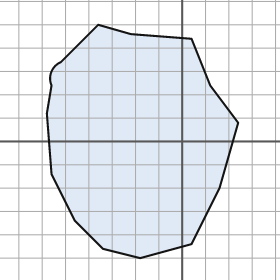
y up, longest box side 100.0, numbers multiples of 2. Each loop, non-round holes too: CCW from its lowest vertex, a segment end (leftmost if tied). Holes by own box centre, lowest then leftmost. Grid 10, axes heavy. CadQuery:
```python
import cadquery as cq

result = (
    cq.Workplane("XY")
    .moveTo(-18.0, -50.0)
    .lineTo(4.0, -44.0)
    .lineTo(16.0, -20.0)
    .lineTo(24.0, 8.0)
    .lineTo(12.0, 24.0)
    .lineTo(4.0, 44.0)
    .lineTo(-22.0, 46.0)
    .lineTo(-36.0, 50.0)
    .lineTo(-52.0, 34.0)
    .threePointArc((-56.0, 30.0), (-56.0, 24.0))
    .lineTo(-58.0, 12.0)
    .lineTo(-56.0, -14.0)
    .lineTo(-46.0, -34.0)
    .lineTo(-34.0, -46.0)
    .close()
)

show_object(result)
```